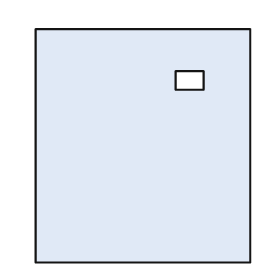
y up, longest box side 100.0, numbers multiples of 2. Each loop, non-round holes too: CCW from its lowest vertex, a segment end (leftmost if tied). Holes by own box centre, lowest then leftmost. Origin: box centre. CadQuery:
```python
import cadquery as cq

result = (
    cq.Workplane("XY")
    .moveTo(-46.0, -50.0)
    .lineTo(46.0, -50.0)
    .lineTo(46.0, 50.0)
    .lineTo(-46.0, 50.0)
    .close()
    .moveTo(14.0, 24.0)
    .lineTo(26.0, 24.0)
    .lineTo(26.0, 32.0)
    .lineTo(14.0, 32.0)
    .close()
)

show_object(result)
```